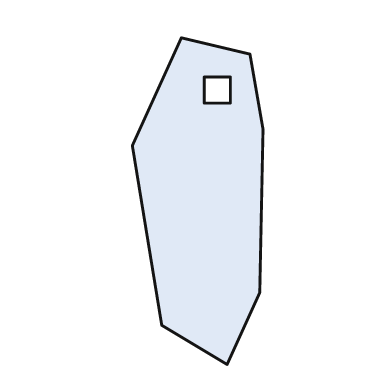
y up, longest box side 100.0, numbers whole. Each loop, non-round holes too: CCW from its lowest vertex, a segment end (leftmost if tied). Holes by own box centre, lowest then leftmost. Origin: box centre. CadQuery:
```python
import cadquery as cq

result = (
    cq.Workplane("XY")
    .moveTo(9.0, -50.0)
    .lineTo(19.0, -28.0)
    .lineTo(20.0, 22.0)
    .lineTo(16.0, 45.0)
    .lineTo(-5.0, 50.0)
    .lineTo(-20.0, 17.0)
    .lineTo(-11.0, -38.0)
    .close()
    .moveTo(2.0, 30.0)
    .lineTo(10.0, 30.0)
    .lineTo(10.0, 38.0)
    .lineTo(2.0, 38.0)
    .close()
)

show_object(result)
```